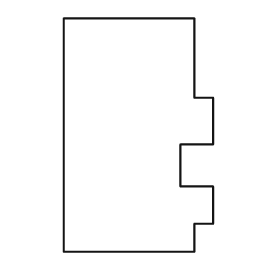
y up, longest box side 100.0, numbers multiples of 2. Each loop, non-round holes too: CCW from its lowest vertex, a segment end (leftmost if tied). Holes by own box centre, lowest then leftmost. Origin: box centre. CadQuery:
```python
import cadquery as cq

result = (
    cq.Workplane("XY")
    .moveTo(-32.0, -50.0)
    .lineTo(24.0, -50.0)
    .lineTo(24.0, -38.0)
    .lineTo(32.0, -38.0)
    .lineTo(32.0, -22.0)
    .lineTo(18.0, -22.0)
    .lineTo(18.0, -4.0)
    .lineTo(32.0, -4.0)
    .lineTo(32.0, 16.0)
    .lineTo(24.0, 16.0)
    .lineTo(24.0, 50.0)
    .lineTo(-32.0, 50.0)
    .close()
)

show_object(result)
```